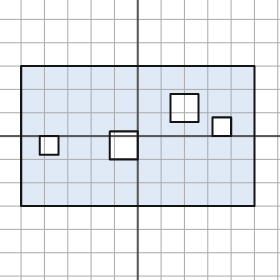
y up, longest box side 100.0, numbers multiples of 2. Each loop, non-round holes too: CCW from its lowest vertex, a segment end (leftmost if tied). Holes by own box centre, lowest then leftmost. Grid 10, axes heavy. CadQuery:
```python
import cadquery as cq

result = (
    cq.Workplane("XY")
    .moveTo(-50.0, -30.0)
    .lineTo(50.0, -30.0)
    .lineTo(50.0, 30.0)
    .lineTo(-50.0, 30.0)
    .close()
    .moveTo(-42.0, -8.0)
    .lineTo(-34.0, -8.0)
    .lineTo(-34.0, 0.0)
    .lineTo(-42.0, 0.0)
    .close()
    .moveTo(-12.0, -10.0)
    .lineTo(0.0, -10.0)
    .lineTo(0.0, 2.0)
    .lineTo(-12.0, 2.0)
    .close()
    .moveTo(32.0, 0.0)
    .lineTo(40.0, 0.0)
    .lineTo(40.0, 8.0)
    .lineTo(32.0, 8.0)
    .close()
    .moveTo(14.0, 6.0)
    .lineTo(26.0, 6.0)
    .lineTo(26.0, 18.0)
    .lineTo(14.0, 18.0)
    .close()
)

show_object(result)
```